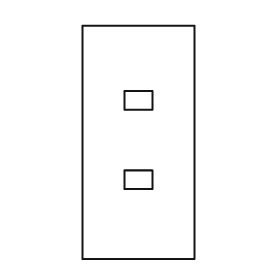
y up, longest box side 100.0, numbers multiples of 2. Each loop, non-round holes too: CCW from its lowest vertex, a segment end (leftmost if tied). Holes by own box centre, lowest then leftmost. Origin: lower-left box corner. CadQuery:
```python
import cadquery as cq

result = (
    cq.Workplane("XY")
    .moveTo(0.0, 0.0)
    .lineTo(48.0, 0.0)
    .lineTo(48.0, 100.0)
    .lineTo(0.0, 100.0)
    .close()
    .moveTo(18.0, 30.0)
    .lineTo(30.0, 30.0)
    .lineTo(30.0, 38.0)
    .lineTo(18.0, 38.0)
    .close()
    .moveTo(18.0, 64.0)
    .lineTo(30.0, 64.0)
    .lineTo(30.0, 72.0)
    .lineTo(18.0, 72.0)
    .close()
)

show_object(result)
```